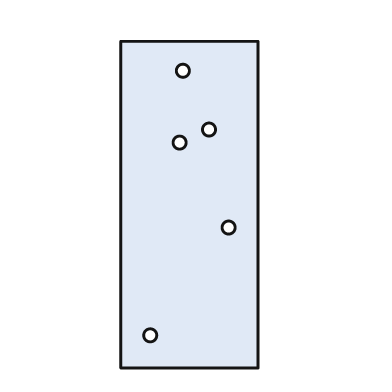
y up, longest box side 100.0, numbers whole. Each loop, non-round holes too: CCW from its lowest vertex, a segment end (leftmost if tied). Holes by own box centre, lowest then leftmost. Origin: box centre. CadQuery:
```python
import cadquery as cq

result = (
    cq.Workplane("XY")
    .moveTo(-21.0, -50.0)
    .lineTo(21.0, -50.0)
    .lineTo(21.0, 50.0)
    .lineTo(-21.0, 50.0)
    .close()
    .moveTo(-12.0, -40.0)
    .circle(2.0)
    .moveTo(12.0, -7.0)
    .circle(2.0)
    .moveTo(-3.0, 19.0)
    .circle(2.0)
    .moveTo(6.0, 23.0)
    .circle(2.0)
    .moveTo(-2.0, 41.0)
    .circle(2.0)
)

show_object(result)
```